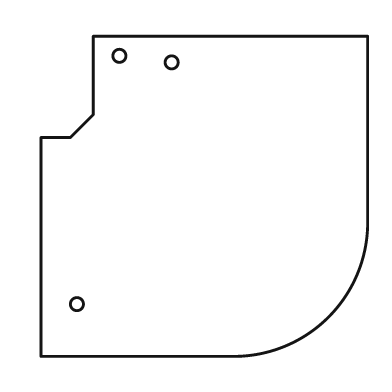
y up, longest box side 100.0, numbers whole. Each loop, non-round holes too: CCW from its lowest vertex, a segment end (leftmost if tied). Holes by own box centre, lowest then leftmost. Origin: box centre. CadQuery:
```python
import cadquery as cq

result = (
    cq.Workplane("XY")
    .moveTo(-50.0, -49.0)
    .lineTo(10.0, -49.0)
    .threePointArc((38.0, -37.0), (50.0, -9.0))
    .lineTo(50.0, 49.0)
    .lineTo(-34.0, 49.0)
    .lineTo(-34.0, 25.0)
    .lineTo(-41.0, 18.0)
    .lineTo(-50.0, 18.0)
    .close()
    .moveTo(-39.0, -33.0)
    .circle(2.0)
    .moveTo(-10.0, 41.0)
    .circle(2.0)
    .moveTo(-26.0, 43.0)
    .circle(2.0)
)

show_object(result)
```